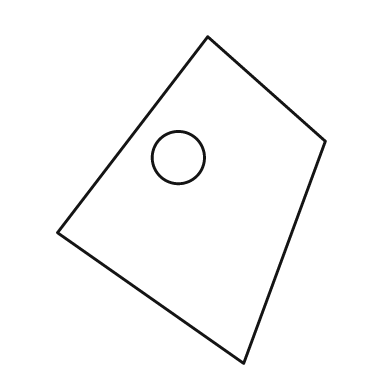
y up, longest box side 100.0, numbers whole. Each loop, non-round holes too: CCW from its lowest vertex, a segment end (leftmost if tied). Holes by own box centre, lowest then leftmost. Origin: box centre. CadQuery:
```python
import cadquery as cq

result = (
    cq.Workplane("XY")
    .moveTo(16.0, -50.0)
    .lineTo(41.0, 18.0)
    .lineTo(5.0, 50.0)
    .lineTo(-41.0, -10.0)
    .close()
    .moveTo(-4.0, 13.0)
    .circle(8.0)
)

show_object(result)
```